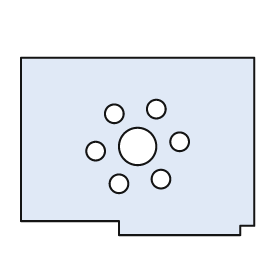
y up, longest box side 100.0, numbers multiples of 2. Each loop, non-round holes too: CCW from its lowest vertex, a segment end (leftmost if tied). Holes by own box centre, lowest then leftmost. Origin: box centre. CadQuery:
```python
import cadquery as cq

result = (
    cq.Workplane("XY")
    .moveTo(-8.0, -38.0)
    .lineTo(44.0, -38.0)
    .lineTo(44.0, -34.0)
    .lineTo(50.0, -34.0)
    .lineTo(50.0, 38.0)
    .lineTo(-50.0, 38.0)
    .lineTo(-50.0, -32.0)
    .lineTo(-8.0, -32.0)
    .close()
    .moveTo(-8.0, -16.0)
    .circle(4.0)
    .moveTo(10.0, -14.0)
    .circle(4.0)
    .moveTo(-18.0, -2.0)
    .circle(4.0)
    .moveTo(0.0, 0.0)
    .circle(8.0)
    .moveTo(18.0, 2.0)
    .circle(4.0)
    .moveTo(-10.0, 14.0)
    .circle(4.0)
    .moveTo(8.0, 16.0)
    .circle(4.0)
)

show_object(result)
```